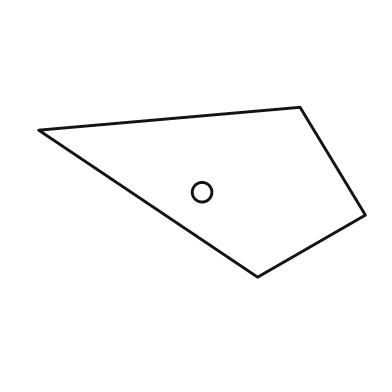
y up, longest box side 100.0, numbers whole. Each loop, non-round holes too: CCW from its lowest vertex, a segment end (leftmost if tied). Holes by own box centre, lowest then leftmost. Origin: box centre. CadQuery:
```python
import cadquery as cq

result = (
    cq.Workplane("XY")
    .moveTo(17.0, -26.0)
    .lineTo(50.0, -7.0)
    .lineTo(30.0, 26.0)
    .lineTo(-50.0, 19.0)
    .close()
    .moveTo(0.0, 0.0)
    .circle(3.0)
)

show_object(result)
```